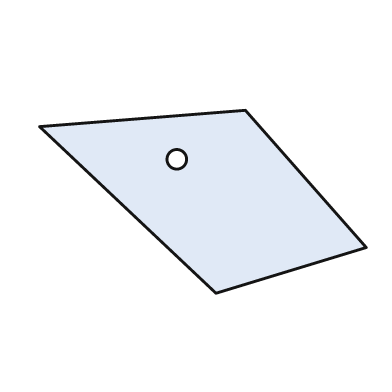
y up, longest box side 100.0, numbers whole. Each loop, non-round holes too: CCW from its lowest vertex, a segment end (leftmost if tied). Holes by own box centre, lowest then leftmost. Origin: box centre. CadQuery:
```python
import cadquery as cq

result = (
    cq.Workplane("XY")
    .moveTo(4.0, -28.0)
    .lineTo(50.0, -14.0)
    .lineTo(13.0, 28.0)
    .lineTo(-50.0, 23.0)
    .close()
    .moveTo(-8.0, 13.0)
    .circle(3.0)
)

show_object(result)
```